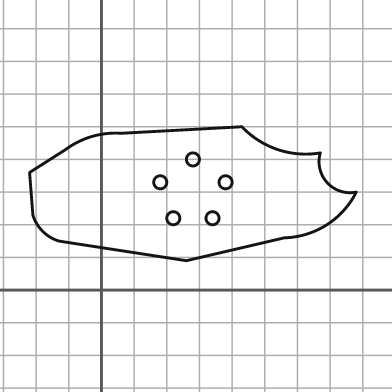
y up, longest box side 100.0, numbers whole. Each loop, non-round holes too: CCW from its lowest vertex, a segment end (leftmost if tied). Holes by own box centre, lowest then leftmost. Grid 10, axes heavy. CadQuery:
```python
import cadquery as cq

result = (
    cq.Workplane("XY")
    .moveTo(26.0, 9.0)
    .lineTo(56.0, 16.0)
    .threePointArc((69.0, 20.0), (78.0, 30.0))
    .threePointArc((69.0, 33.0), (67.0, 42.0))
    .threePointArc((54.0, 43.0), (43.0, 50.0))
    .lineTo(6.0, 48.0)
    .threePointArc((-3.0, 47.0), (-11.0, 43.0))
    .lineTo(-22.0, 36.0)
    .lineTo(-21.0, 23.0)
    .threePointArc((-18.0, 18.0), (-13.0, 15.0))
    .close()
    .moveTo(22.0, 22.0)
    .circle(2.0)
    .moveTo(34.0, 22.0)
    .circle(2.0)
    .moveTo(18.0, 33.0)
    .circle(2.0)
    .moveTo(38.0, 33.0)
    .circle(2.0)
    .moveTo(28.0, 40.0)
    .circle(2.0)
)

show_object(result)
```